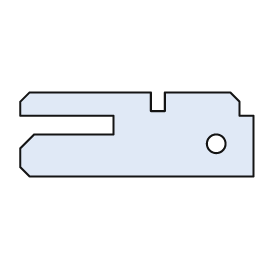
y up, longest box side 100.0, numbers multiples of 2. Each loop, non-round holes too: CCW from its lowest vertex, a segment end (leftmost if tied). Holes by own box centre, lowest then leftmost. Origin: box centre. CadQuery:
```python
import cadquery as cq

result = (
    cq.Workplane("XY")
    .moveTo(-46.0, -18.0)
    .lineTo(50.0, -18.0)
    .lineTo(50.0, 8.0)
    .lineTo(44.0, 8.0)
    .lineTo(44.0, 14.0)
    .lineTo(40.0, 18.0)
    .lineTo(12.0, 18.0)
    .lineTo(12.0, 10.0)
    .lineTo(6.0, 10.0)
    .lineTo(6.0, 18.0)
    .lineTo(-46.0, 18.0)
    .lineTo(-50.0, 14.0)
    .lineTo(-50.0, 8.0)
    .lineTo(-10.0, 8.0)
    .lineTo(-10.0, 0.0)
    .lineTo(-44.0, 0.0)
    .lineTo(-50.0, -6.0)
    .lineTo(-50.0, -14.0)
    .close()
    .moveTo(34.0, -4.0)
    .circle(4.0)
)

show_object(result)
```